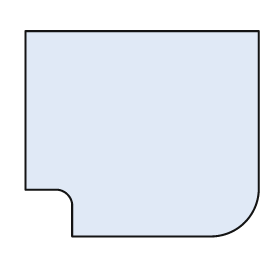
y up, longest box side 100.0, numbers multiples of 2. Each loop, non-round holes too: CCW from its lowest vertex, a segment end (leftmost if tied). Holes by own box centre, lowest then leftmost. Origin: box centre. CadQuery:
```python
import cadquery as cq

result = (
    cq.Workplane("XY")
    .moveTo(-30.0, -44.0)
    .lineTo(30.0, -44.0)
    .threePointArc((44.0, -38.0), (50.0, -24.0))
    .lineTo(50.0, 44.0)
    .lineTo(-50.0, 44.0)
    .lineTo(-50.0, -24.0)
    .lineTo(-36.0, -24.0)
    .threePointArc((-32.0, -26.0), (-30.0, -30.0))
    .close()
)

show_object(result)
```